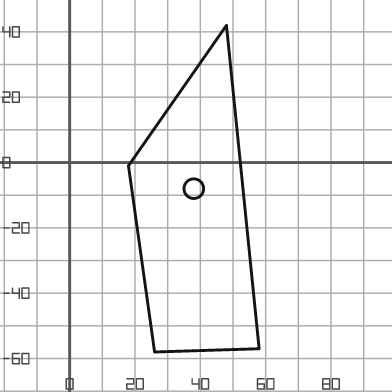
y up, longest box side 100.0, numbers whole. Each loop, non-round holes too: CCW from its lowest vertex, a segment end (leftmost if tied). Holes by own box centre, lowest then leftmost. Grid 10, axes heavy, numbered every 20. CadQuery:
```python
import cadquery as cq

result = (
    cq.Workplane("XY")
    .moveTo(26.0, -58.0)
    .lineTo(58.0, -57.0)
    .lineTo(48.0, 42.0)
    .lineTo(18.0, -1.0)
    .close()
    .moveTo(38.0, -8.0)
    .circle(3.0)
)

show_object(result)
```